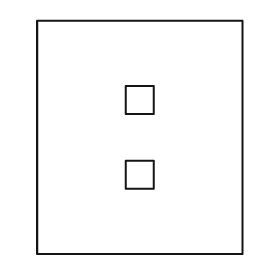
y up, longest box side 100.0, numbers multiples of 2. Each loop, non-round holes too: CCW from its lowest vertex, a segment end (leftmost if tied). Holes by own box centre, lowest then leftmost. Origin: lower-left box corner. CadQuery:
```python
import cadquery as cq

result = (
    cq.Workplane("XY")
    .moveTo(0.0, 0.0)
    .lineTo(88.0, 0.0)
    .lineTo(88.0, 100.0)
    .lineTo(0.0, 100.0)
    .close()
    .moveTo(38.0, 28.0)
    .lineTo(50.0, 28.0)
    .lineTo(50.0, 40.0)
    .lineTo(38.0, 40.0)
    .close()
    .moveTo(38.0, 60.0)
    .lineTo(50.0, 60.0)
    .lineTo(50.0, 72.0)
    .lineTo(38.0, 72.0)
    .close()
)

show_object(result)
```